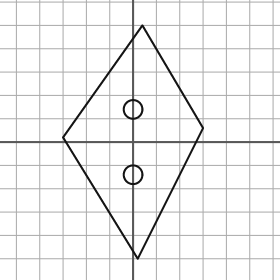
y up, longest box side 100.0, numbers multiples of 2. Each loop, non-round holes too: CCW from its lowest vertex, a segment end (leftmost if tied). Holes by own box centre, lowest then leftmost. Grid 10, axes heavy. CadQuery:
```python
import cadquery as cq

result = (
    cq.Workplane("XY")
    .moveTo(2.0, -50.0)
    .lineTo(30.0, 6.0)
    .lineTo(4.0, 50.0)
    .lineTo(-30.0, 2.0)
    .close()
    .moveTo(0.0, -14.0)
    .circle(4.0)
    .moveTo(0.0, 14.0)
    .circle(4.0)
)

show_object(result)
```